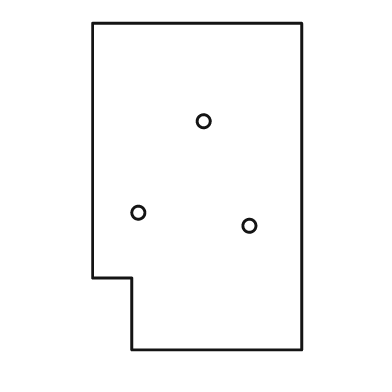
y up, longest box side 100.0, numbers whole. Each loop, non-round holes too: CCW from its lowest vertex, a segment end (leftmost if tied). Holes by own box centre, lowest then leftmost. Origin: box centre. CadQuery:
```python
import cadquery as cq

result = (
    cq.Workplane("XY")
    .moveTo(-20.0, -50.0)
    .lineTo(32.0, -50.0)
    .lineTo(32.0, 50.0)
    .lineTo(-32.0, 50.0)
    .lineTo(-32.0, -28.0)
    .lineTo(-20.0, -28.0)
    .close()
    .moveTo(16.0, -12.0)
    .circle(2.0)
    .moveTo(-18.0, -8.0)
    .circle(2.0)
    .moveTo(2.0, 20.0)
    .circle(2.0)
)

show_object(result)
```